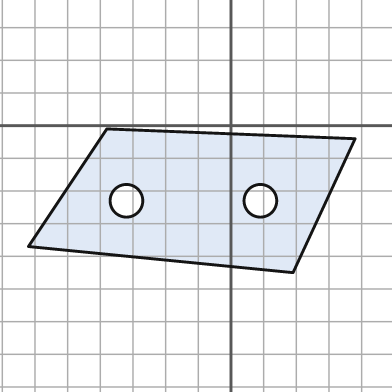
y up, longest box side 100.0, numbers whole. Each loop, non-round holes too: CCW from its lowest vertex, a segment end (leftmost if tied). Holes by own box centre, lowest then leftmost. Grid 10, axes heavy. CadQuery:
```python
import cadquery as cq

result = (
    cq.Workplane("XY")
    .moveTo(19.0, -45.0)
    .lineTo(38.0, -4.0)
    .lineTo(-38.0, -1.0)
    .lineTo(-62.0, -37.0)
    .close()
    .moveTo(-32.0, -23.0)
    .circle(5.0)
    .moveTo(9.0, -23.0)
    .circle(5.0)
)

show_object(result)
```